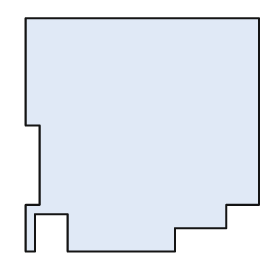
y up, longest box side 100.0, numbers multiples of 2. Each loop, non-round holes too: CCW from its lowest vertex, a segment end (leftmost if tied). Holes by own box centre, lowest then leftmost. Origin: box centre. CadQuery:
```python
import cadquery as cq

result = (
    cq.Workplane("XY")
    .moveTo(-50.0, -50.0)
    .lineTo(-46.0, -50.0)
    .lineTo(-46.0, -34.0)
    .lineTo(-32.0, -34.0)
    .lineTo(-32.0, -50.0)
    .lineTo(14.0, -50.0)
    .lineTo(14.0, -40.0)
    .lineTo(36.0, -40.0)
    .lineTo(36.0, -30.0)
    .lineTo(50.0, -30.0)
    .lineTo(50.0, 50.0)
    .lineTo(-50.0, 50.0)
    .lineTo(-50.0, 4.0)
    .lineTo(-44.0, 4.0)
    .lineTo(-44.0, -30.0)
    .lineTo(-50.0, -30.0)
    .close()
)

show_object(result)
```